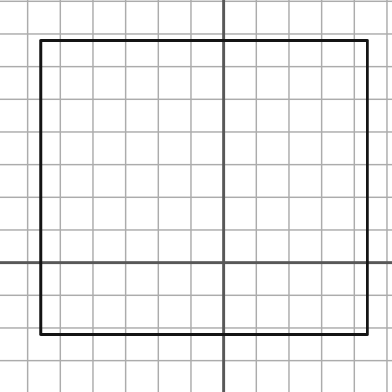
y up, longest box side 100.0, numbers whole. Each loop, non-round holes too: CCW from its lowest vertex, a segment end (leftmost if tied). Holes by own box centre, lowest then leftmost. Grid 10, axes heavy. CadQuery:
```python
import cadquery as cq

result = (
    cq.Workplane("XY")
    .moveTo(-56.0, -22.0)
    .lineTo(44.0, -22.0)
    .lineTo(44.0, 68.0)
    .lineTo(-56.0, 68.0)
    .close()
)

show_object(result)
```